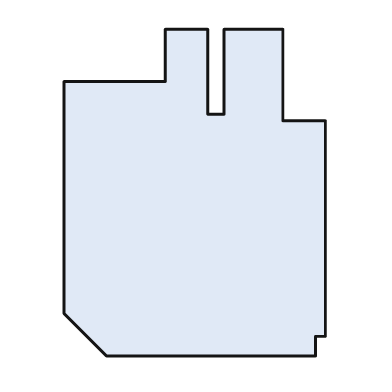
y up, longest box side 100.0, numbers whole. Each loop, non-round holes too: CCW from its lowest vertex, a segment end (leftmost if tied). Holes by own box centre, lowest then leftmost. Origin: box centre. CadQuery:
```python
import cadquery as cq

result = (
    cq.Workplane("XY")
    .moveTo(-27.0, -50.0)
    .lineTo(37.0, -50.0)
    .lineTo(37.0, -44.0)
    .lineTo(40.0, -44.0)
    .lineTo(40.0, 22.0)
    .lineTo(27.0, 22.0)
    .lineTo(27.0, 50.0)
    .lineTo(9.0, 50.0)
    .lineTo(9.0, 24.0)
    .lineTo(4.0, 24.0)
    .lineTo(4.0, 50.0)
    .lineTo(-9.0, 50.0)
    .lineTo(-9.0, 34.0)
    .lineTo(-40.0, 34.0)
    .lineTo(-40.0, -37.0)
    .close()
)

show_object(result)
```